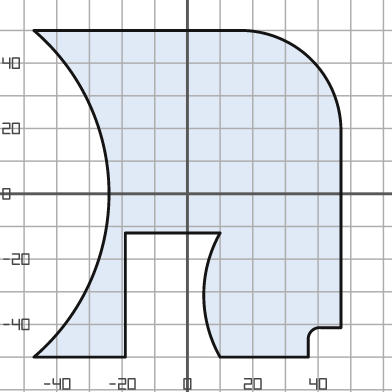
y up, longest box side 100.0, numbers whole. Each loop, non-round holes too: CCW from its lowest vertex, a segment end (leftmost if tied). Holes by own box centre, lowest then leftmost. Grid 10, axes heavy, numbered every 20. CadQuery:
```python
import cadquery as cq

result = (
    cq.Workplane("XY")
    .moveTo(-47.0, -50.0)
    .lineTo(-19.0, -50.0)
    .lineTo(-19.0, -12.0)
    .lineTo(10.0, -12.0)
    .threePointArc((5.0, -31.0), (10.0, -50.0))
    .lineTo(37.0, -50.0)
    .lineTo(37.0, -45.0)
    .threePointArc((38.0, -42.0), (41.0, -41.0))
    .lineTo(47.0, -41.0)
    .lineTo(47.0, 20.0)
    .threePointArc((38.0, 41.0), (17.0, 50.0))
    .lineTo(-47.0, 50.0)
    .threePointArc((-24.0, 0.0), (-47.0, -50.0))
    .close()
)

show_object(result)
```